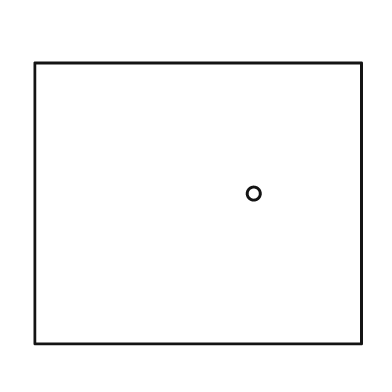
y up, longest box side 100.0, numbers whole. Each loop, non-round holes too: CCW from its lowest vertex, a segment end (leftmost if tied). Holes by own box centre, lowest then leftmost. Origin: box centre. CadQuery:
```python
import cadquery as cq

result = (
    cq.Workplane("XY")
    .moveTo(-50.0, -43.0)
    .lineTo(50.0, -43.0)
    .lineTo(50.0, 43.0)
    .lineTo(-50.0, 43.0)
    .close()
    .moveTo(17.0, 3.0)
    .circle(2.0)
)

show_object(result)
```